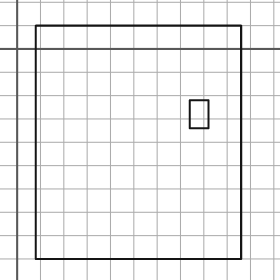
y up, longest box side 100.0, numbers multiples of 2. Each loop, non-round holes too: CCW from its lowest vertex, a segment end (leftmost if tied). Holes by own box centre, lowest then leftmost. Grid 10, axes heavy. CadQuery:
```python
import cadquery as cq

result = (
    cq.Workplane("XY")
    .moveTo(8.0, -90.0)
    .lineTo(96.0, -90.0)
    .lineTo(96.0, 10.0)
    .lineTo(8.0, 10.0)
    .close()
    .moveTo(74.0, -34.0)
    .lineTo(82.0, -34.0)
    .lineTo(82.0, -22.0)
    .lineTo(74.0, -22.0)
    .close()
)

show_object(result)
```